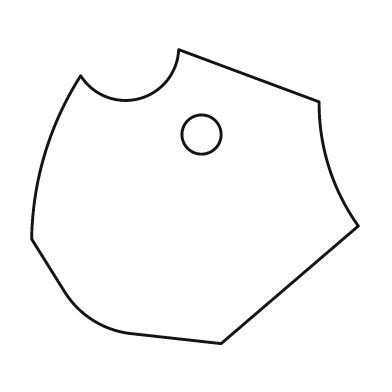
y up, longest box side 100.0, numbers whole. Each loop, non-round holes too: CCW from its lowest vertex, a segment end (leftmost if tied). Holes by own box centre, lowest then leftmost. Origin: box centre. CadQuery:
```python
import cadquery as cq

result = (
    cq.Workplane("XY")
    .moveTo(8.0, -45.0)
    .lineTo(50.0, -9.0)
    .threePointArc((41.0, 9.0), (38.0, 29.0))
    .lineTo(-5.0, 45.0)
    .threePointArc((-17.0, 30.0), (-35.0, 37.0))
    .threePointArc((-46.0, 13.0), (-50.0, -13.0))
    .lineTo(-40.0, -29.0)
    .threePointArc((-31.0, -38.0), (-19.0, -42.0))
    .close()
    .moveTo(2.0, 19.0)
    .circle(6.0)
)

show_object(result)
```